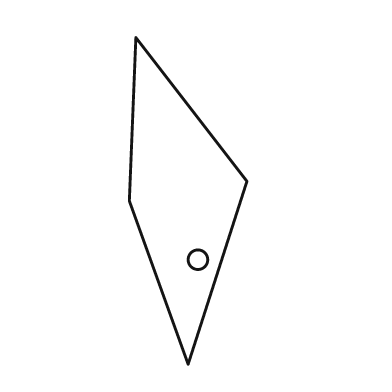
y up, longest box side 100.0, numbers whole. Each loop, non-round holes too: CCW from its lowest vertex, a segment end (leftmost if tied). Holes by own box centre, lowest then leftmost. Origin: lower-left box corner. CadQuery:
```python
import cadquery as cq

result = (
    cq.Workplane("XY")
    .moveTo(18.0, 0.0)
    .lineTo(36.0, 56.0)
    .lineTo(2.0, 100.0)
    .lineTo(0.0, 50.0)
    .close()
    .moveTo(21.0, 32.0)
    .circle(3.0)
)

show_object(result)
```